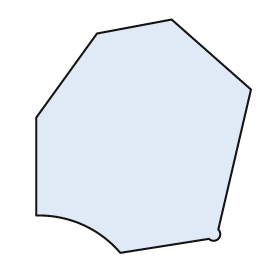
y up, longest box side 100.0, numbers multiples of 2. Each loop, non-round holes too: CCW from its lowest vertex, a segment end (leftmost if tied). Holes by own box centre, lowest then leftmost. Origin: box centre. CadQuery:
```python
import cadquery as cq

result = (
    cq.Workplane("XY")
    .moveTo(-10.0, -50.0)
    .lineTo(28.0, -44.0)
    .threePointArc((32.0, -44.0), (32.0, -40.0))
    .lineTo(46.0, 20.0)
    .lineTo(12.0, 50.0)
    .lineTo(-20.0, 44.0)
    .lineTo(-46.0, 8.0)
    .lineTo(-46.0, -34.0)
    .threePointArc((-26.0, -38.0), (-10.0, -50.0))
    .close()
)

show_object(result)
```